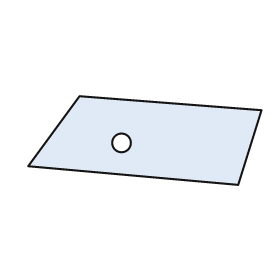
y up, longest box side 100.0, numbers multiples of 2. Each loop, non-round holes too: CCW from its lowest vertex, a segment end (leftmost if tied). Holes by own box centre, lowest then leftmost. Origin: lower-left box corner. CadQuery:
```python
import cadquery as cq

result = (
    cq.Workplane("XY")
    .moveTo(90.0, 0.0)
    .lineTo(100.0, 32.0)
    .lineTo(22.0, 38.0)
    .lineTo(0.0, 8.0)
    .close()
    .moveTo(40.0, 18.0)
    .circle(4.0)
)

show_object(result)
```